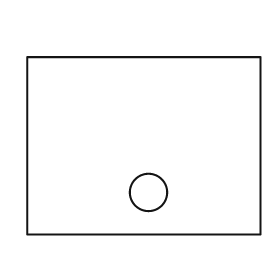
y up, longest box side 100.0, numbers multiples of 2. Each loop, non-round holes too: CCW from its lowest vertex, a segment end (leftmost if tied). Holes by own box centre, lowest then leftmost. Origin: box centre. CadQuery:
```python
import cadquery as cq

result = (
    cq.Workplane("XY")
    .moveTo(-50.0, -38.0)
    .lineTo(50.0, -38.0)
    .lineTo(50.0, 38.0)
    .lineTo(-50.0, 38.0)
    .close()
    .moveTo(2.0, -20.0)
    .circle(8.0)
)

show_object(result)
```